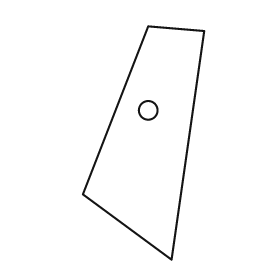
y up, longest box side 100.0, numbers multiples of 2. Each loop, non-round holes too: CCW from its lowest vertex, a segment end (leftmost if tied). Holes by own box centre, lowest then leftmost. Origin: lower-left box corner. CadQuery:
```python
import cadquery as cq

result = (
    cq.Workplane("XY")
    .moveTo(38.0, 0.0)
    .lineTo(52.0, 98.0)
    .lineTo(28.0, 100.0)
    .lineTo(0.0, 28.0)
    .close()
    .moveTo(28.0, 64.0)
    .circle(4.0)
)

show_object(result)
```